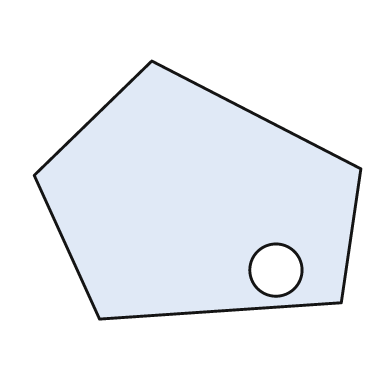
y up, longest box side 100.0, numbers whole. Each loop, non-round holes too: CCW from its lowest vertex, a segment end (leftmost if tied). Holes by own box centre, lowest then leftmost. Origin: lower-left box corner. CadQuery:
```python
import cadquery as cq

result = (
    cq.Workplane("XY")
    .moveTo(20.0, 0.0)
    .lineTo(94.0, 5.0)
    .lineTo(100.0, 46.0)
    .lineTo(36.0, 79.0)
    .lineTo(0.0, 44.0)
    .close()
    .moveTo(74.0, 15.0)
    .circle(8.0)
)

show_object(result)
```